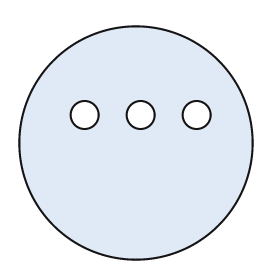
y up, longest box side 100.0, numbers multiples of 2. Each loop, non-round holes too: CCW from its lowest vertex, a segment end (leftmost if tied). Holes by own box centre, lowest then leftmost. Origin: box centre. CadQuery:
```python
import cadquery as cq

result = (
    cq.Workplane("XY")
    .moveTo(0.0, 0.0)
    .circle(50.0)
    .moveTo(-22.0, 12.0)
    .circle(6.0)
    .moveTo(2.0, 12.0)
    .circle(6.0)
    .moveTo(26.0, 12.0)
    .circle(6.0)
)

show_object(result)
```